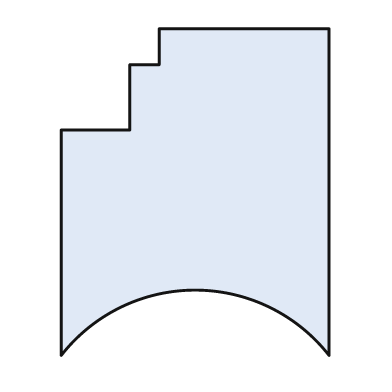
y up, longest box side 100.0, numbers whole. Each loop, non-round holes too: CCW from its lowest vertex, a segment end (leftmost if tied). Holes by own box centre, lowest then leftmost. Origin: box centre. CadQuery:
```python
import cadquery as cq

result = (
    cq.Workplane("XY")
    .moveTo(-41.0, -50.0)
    .threePointArc((0.0, -30.0), (41.0, -50.0))
    .lineTo(41.0, 50.0)
    .lineTo(-11.0, 50.0)
    .lineTo(-11.0, 39.0)
    .lineTo(-20.0, 39.0)
    .lineTo(-20.0, 19.0)
    .lineTo(-41.0, 19.0)
    .close()
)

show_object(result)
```